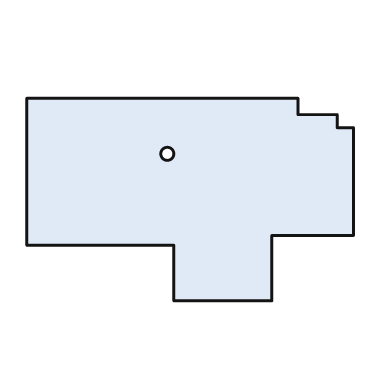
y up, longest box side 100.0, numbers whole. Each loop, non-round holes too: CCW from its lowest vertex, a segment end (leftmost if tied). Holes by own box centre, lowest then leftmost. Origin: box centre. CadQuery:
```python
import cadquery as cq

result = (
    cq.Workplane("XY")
    .moveTo(-5.0, -31.0)
    .lineTo(25.0, -31.0)
    .lineTo(25.0, -11.0)
    .lineTo(50.0, -11.0)
    .lineTo(50.0, 22.0)
    .lineTo(45.0, 22.0)
    .lineTo(45.0, 26.0)
    .lineTo(33.0, 26.0)
    .lineTo(33.0, 31.0)
    .lineTo(-50.0, 31.0)
    .lineTo(-50.0, -14.0)
    .lineTo(-5.0, -14.0)
    .close()
    .moveTo(-7.0, 14.0)
    .circle(2.0)
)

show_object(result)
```